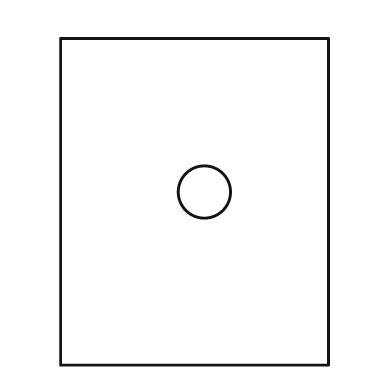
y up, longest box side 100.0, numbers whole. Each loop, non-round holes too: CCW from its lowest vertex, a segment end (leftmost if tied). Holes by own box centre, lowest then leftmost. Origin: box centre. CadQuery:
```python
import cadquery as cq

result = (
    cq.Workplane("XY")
    .moveTo(-41.0, -50.0)
    .lineTo(41.0, -50.0)
    .lineTo(41.0, 50.0)
    .lineTo(-41.0, 50.0)
    .close()
    .moveTo(3.0, 3.0)
    .circle(8.0)
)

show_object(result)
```